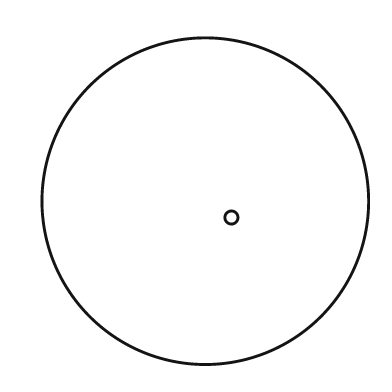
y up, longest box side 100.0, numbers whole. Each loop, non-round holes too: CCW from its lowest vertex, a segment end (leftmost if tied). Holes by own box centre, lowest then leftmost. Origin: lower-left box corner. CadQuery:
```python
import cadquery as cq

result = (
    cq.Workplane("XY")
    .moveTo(50.0, 50.0)
    .circle(50.0)
    .moveTo(58.0, 45.0)
    .circle(2.0)
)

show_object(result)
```